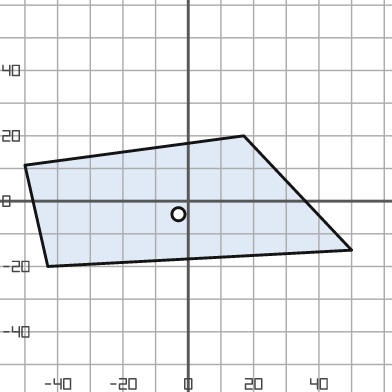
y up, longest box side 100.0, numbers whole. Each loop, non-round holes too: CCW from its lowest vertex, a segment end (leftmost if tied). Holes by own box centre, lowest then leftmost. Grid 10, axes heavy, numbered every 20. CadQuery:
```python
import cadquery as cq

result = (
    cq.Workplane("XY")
    .moveTo(-43.0, -20.0)
    .lineTo(50.0, -15.0)
    .lineTo(17.0, 20.0)
    .lineTo(-50.0, 11.0)
    .close()
    .moveTo(-3.0, -4.0)
    .circle(2.0)
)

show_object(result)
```